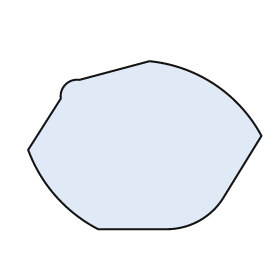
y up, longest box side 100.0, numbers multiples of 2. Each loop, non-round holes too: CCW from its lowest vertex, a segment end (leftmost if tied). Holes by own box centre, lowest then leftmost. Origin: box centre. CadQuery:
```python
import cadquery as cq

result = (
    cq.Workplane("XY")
    .moveTo(-20.0, -36.0)
    .lineTo(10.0, -36.0)
    .threePointArc((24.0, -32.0), (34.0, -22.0))
    .lineTo(50.0, 4.0)
    .threePointArc((30.0, 26.0), (2.0, 36.0))
    .lineTo(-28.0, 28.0)
    .threePointArc((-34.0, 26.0), (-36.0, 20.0))
    .lineTo(-50.0, -2.0)
    .threePointArc((-38.0, -22.0), (-20.0, -36.0))
    .close()
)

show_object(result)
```